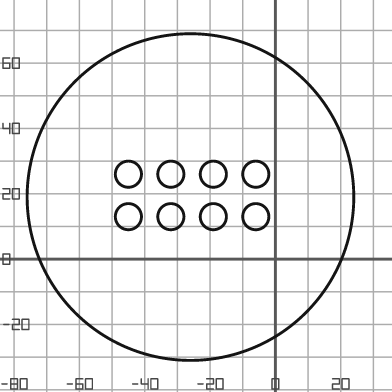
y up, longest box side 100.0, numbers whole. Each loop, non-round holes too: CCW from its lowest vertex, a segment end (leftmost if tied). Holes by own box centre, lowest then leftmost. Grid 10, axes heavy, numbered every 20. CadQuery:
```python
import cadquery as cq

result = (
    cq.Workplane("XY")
    .moveTo(-26.0, 19.0)
    .circle(50.0)
    .moveTo(-45.0, 13.0)
    .circle(4.0)
    .moveTo(-32.0, 13.0)
    .circle(4.0)
    .moveTo(-19.0, 13.0)
    .circle(4.0)
    .moveTo(-6.0, 13.0)
    .circle(4.0)
    .moveTo(-45.0, 26.0)
    .circle(4.0)
    .moveTo(-32.0, 26.0)
    .circle(4.0)
    .moveTo(-19.0, 26.0)
    .circle(4.0)
    .moveTo(-6.0, 26.0)
    .circle(4.0)
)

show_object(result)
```